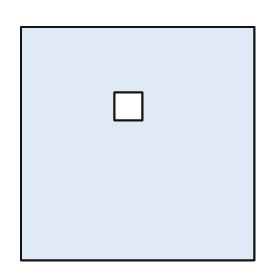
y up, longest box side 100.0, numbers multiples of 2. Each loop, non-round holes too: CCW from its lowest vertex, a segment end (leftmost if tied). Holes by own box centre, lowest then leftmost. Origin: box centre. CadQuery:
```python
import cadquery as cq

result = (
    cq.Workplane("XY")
    .moveTo(-50.0, -50.0)
    .lineTo(50.0, -50.0)
    .lineTo(50.0, 50.0)
    .lineTo(-50.0, 50.0)
    .close()
    .moveTo(-10.0, 10.0)
    .lineTo(2.0, 10.0)
    .lineTo(2.0, 22.0)
    .lineTo(-10.0, 22.0)
    .close()
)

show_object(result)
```